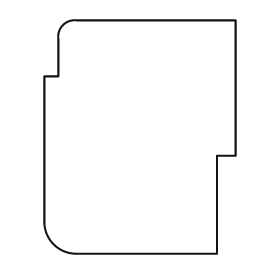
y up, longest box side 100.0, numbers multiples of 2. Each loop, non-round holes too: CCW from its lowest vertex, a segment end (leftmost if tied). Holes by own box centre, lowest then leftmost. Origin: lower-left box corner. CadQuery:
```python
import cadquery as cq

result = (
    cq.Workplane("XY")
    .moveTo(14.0, 0.0)
    .lineTo(74.0, 0.0)
    .lineTo(74.0, 42.0)
    .lineTo(82.0, 42.0)
    .lineTo(82.0, 100.0)
    .lineTo(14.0, 100.0)
    .threePointArc((8.0, 98.0), (6.0, 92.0))
    .lineTo(6.0, 76.0)
    .lineTo(0.0, 76.0)
    .lineTo(0.0, 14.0)
    .threePointArc((4.0, 4.0), (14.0, 0.0))
    .close()
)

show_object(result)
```